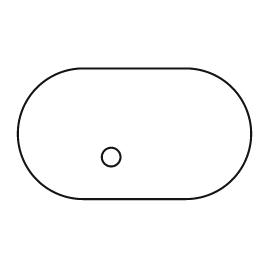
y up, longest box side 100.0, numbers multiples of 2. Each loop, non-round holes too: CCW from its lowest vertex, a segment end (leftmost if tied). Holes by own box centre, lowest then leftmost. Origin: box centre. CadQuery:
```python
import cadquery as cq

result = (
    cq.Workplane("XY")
    .moveTo(-22.0, -28.0)
    .lineTo(22.0, -28.0)
    .threePointArc((50.0, 0.0), (22.0, 28.0))
    .lineTo(-22.0, 28.0)
    .threePointArc((-50.0, 0.0), (-22.0, -28.0))
    .close()
    .moveTo(-10.0, -10.0)
    .circle(4.0)
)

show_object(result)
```